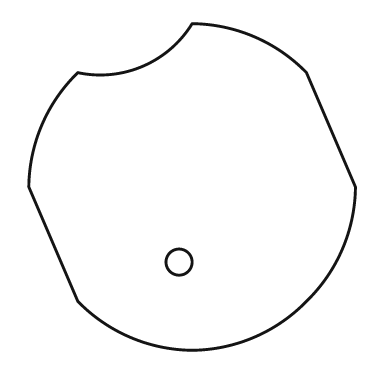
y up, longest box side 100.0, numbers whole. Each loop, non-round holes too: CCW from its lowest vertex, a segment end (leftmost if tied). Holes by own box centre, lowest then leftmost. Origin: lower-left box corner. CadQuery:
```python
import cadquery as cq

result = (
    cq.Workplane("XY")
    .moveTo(50.0, 0.0)
    .threePointArc((69.0, 4.0), (85.0, 15.0))
    .threePointArc((96.0, 31.0), (100.0, 50.0))
    .lineTo(85.0, 85.0)
    .threePointArc((69.0, 96.0), (50.0, 100.0))
    .threePointArc((35.0, 87.0), (15.0, 85.0))
    .threePointArc((4.0, 69.0), (0.0, 50.0))
    .lineTo(15.0, 15.0)
    .threePointArc((31.0, 4.0), (50.0, 0.0))
    .close()
    .moveTo(46.0, 27.0)
    .circle(4.0)
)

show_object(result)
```